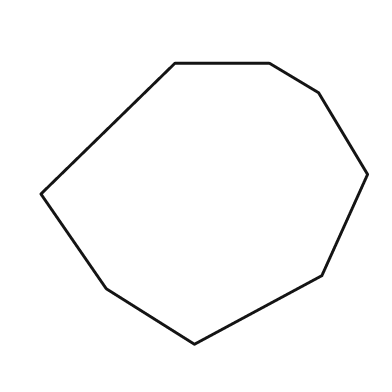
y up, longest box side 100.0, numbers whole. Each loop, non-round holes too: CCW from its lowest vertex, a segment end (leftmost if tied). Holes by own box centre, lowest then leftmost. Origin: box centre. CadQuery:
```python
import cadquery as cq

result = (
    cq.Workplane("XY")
    .moveTo(-3.0, -43.0)
    .lineTo(36.0, -22.0)
    .lineTo(50.0, 9.0)
    .lineTo(35.0, 34.0)
    .lineTo(20.0, 43.0)
    .lineTo(-9.0, 43.0)
    .lineTo(-50.0, 3.0)
    .lineTo(-30.0, -26.0)
    .close()
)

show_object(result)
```